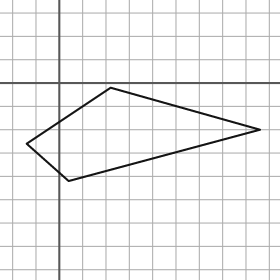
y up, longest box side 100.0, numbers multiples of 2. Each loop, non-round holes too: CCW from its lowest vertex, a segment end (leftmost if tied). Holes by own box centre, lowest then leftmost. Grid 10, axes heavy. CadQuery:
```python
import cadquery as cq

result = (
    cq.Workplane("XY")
    .moveTo(4.0, -42.0)
    .lineTo(86.0, -20.0)
    .lineTo(22.0, -2.0)
    .lineTo(-14.0, -26.0)
    .close()
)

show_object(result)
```